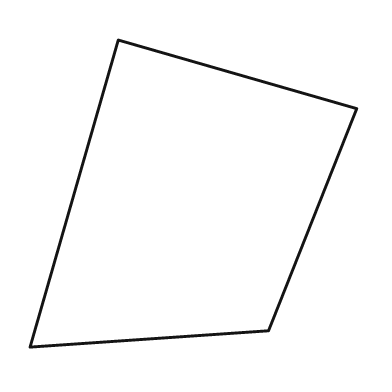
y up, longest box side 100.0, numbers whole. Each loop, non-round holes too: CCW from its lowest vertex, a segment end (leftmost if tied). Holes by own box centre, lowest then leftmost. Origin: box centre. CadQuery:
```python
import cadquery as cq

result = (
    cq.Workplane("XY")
    .moveTo(-50.0, -47.0)
    .lineTo(23.0, -42.0)
    .lineTo(50.0, 26.0)
    .lineTo(-23.0, 47.0)
    .close()
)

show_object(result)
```